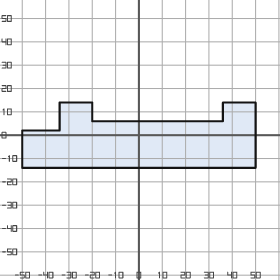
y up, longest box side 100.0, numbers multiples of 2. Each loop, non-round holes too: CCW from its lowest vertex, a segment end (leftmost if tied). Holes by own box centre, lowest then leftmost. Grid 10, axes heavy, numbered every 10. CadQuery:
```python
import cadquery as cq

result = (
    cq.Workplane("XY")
    .moveTo(-50.0, -14.0)
    .lineTo(50.0, -14.0)
    .lineTo(50.0, 14.0)
    .lineTo(36.0, 14.0)
    .lineTo(36.0, 6.0)
    .lineTo(-20.0, 6.0)
    .lineTo(-20.0, 14.0)
    .lineTo(-34.0, 14.0)
    .lineTo(-34.0, 2.0)
    .lineTo(-50.0, 2.0)
    .close()
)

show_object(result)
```